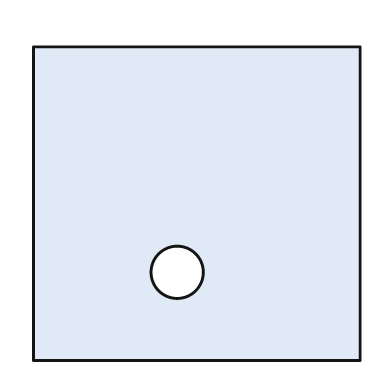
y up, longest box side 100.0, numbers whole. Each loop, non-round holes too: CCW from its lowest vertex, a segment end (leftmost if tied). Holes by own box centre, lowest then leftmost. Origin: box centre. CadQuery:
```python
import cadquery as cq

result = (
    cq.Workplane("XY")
    .moveTo(-50.0, -48.0)
    .lineTo(50.0, -48.0)
    .lineTo(50.0, 48.0)
    .lineTo(-50.0, 48.0)
    .close()
    .moveTo(-6.0, -21.0)
    .circle(8.0)
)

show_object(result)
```